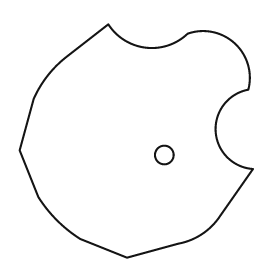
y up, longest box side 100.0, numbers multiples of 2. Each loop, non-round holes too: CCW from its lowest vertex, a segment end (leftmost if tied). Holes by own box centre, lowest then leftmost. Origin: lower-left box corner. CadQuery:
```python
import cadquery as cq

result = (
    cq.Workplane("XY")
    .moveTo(46.0, 0.0)
    .lineTo(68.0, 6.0)
    .threePointArc((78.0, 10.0), (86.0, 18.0))
    .lineTo(100.0, 38.0)
    .threePointArc((84.0, 54.0), (98.0, 72.0))
    .threePointArc((92.0, 92.0), (72.0, 96.0))
    .threePointArc((54.0, 90.0), (38.0, 100.0))
    .lineTo(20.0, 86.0)
    .threePointArc((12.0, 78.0), (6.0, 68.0))
    .lineTo(0.0, 46.0)
    .lineTo(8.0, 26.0)
    .threePointArc((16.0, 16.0), (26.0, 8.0))
    .close()
    .moveTo(62.0, 44.0)
    .circle(4.0)
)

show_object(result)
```